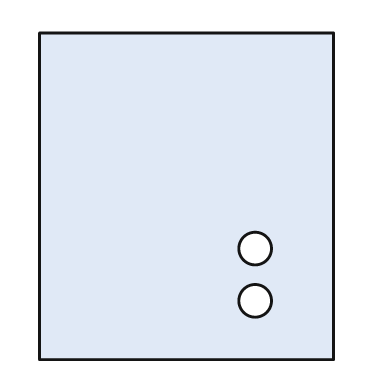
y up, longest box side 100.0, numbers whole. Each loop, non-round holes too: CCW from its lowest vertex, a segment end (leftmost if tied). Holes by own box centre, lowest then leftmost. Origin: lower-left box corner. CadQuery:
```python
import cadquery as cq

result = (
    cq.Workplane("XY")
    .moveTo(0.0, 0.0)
    .lineTo(90.0, 0.0)
    .lineTo(90.0, 100.0)
    .lineTo(0.0, 100.0)
    .close()
    .moveTo(66.0, 18.0)
    .circle(5.0)
    .moveTo(66.0, 34.0)
    .circle(5.0)
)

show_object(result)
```